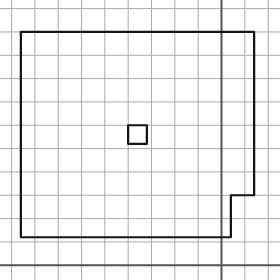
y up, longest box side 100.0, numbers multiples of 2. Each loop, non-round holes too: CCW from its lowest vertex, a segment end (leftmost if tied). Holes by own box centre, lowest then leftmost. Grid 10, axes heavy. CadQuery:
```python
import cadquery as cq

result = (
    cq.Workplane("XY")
    .moveTo(-86.0, 12.0)
    .lineTo(4.0, 12.0)
    .lineTo(4.0, 30.0)
    .lineTo(14.0, 30.0)
    .lineTo(14.0, 100.0)
    .lineTo(-86.0, 100.0)
    .close()
    .moveTo(-40.0, 52.0)
    .lineTo(-32.0, 52.0)
    .lineTo(-32.0, 60.0)
    .lineTo(-40.0, 60.0)
    .close()
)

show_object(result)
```